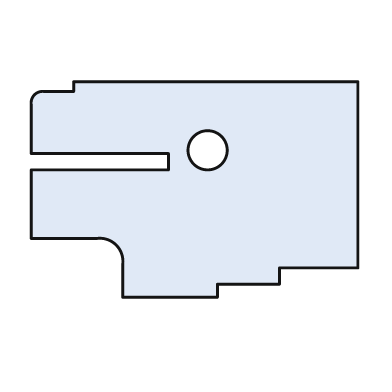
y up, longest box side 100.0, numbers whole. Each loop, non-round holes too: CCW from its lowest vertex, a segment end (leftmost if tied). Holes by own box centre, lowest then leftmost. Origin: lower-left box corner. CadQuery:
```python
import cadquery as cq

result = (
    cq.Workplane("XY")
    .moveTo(28.0, 0.0)
    .lineTo(57.0, 0.0)
    .lineTo(57.0, 4.0)
    .lineTo(76.0, 4.0)
    .lineTo(76.0, 9.0)
    .lineTo(100.0, 9.0)
    .lineTo(100.0, 66.0)
    .lineTo(13.0, 66.0)
    .lineTo(13.0, 63.0)
    .lineTo(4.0, 63.0)
    .threePointArc((1.0, 62.0), (0.0, 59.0))
    .lineTo(0.0, 44.0)
    .lineTo(42.0, 44.0)
    .lineTo(42.0, 39.0)
    .lineTo(0.0, 39.0)
    .lineTo(0.0, 18.0)
    .lineTo(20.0, 18.0)
    .threePointArc((26.0, 16.0), (28.0, 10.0))
    .close()
    .moveTo(54.0, 45.0)
    .circle(6.0)
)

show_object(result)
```